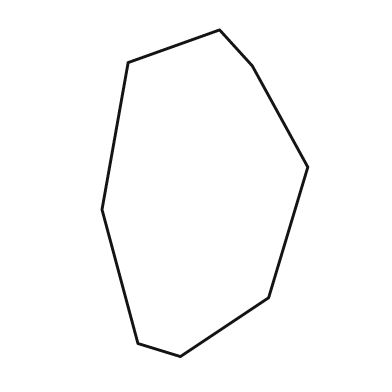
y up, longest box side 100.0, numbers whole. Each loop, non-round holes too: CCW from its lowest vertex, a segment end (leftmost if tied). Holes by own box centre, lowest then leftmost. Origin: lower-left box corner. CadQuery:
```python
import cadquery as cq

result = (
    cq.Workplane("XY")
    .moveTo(24.0, 0.0)
    .lineTo(51.0, 18.0)
    .lineTo(63.0, 58.0)
    .lineTo(46.0, 89.0)
    .lineTo(36.0, 100.0)
    .lineTo(8.0, 90.0)
    .lineTo(0.0, 45.0)
    .lineTo(11.0, 4.0)
    .close()
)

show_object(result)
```